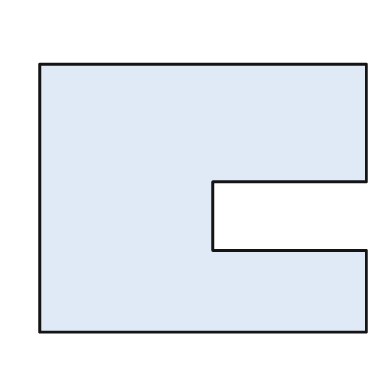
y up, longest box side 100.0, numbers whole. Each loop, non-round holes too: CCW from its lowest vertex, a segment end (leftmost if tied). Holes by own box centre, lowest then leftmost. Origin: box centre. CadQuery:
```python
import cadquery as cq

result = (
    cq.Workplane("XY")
    .moveTo(-50.0, -41.0)
    .lineTo(50.0, -41.0)
    .lineTo(50.0, -16.0)
    .lineTo(3.0, -16.0)
    .lineTo(3.0, 5.0)
    .lineTo(50.0, 5.0)
    .lineTo(50.0, 41.0)
    .lineTo(-50.0, 41.0)
    .close()
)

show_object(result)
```